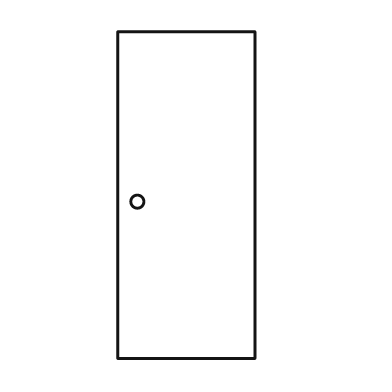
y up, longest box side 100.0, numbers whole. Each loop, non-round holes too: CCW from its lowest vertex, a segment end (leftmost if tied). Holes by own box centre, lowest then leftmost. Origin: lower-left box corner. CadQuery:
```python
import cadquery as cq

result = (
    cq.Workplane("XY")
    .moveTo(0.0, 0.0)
    .lineTo(42.0, 0.0)
    .lineTo(42.0, 100.0)
    .lineTo(0.0, 100.0)
    .close()
    .moveTo(6.0, 48.0)
    .circle(2.0)
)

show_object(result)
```